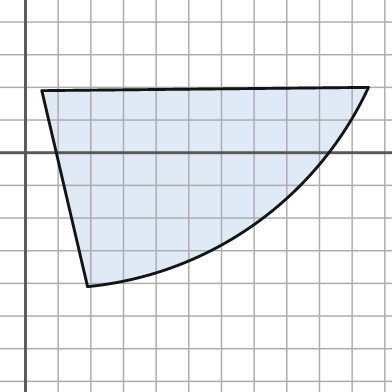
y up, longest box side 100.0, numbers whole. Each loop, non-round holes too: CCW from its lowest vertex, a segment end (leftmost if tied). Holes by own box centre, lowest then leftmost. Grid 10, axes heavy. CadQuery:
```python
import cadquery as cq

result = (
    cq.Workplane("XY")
    .moveTo(19.0, -41.0)
    .threePointArc((70.0, -22.0), (105.0, 20.0))
    .lineTo(5.0, 19.0)
    .close()
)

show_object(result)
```